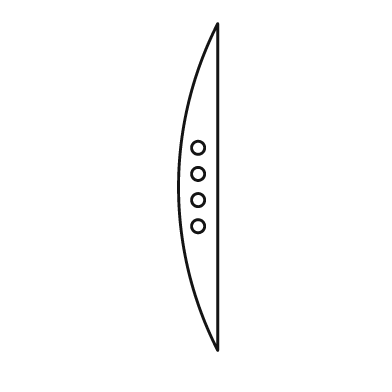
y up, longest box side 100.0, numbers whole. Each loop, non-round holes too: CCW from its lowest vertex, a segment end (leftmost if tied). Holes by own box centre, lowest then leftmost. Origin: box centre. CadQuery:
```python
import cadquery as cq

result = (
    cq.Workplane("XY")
    .moveTo(6.0, -50.0)
    .lineTo(6.0, 50.0)
    .threePointArc((-6.0, 0.0), (6.0, -50.0))
    .close()
    .moveTo(0.0, -12.0)
    .circle(2.0)
    .moveTo(0.0, -4.0)
    .circle(2.0)
    .moveTo(0.0, 4.0)
    .circle(2.0)
    .moveTo(0.0, 12.0)
    .circle(2.0)
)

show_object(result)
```